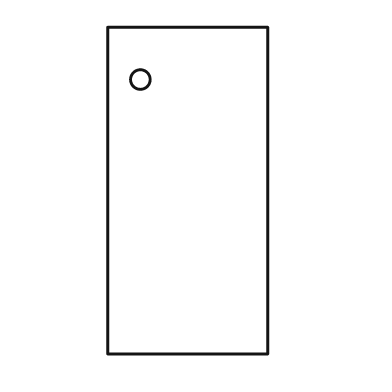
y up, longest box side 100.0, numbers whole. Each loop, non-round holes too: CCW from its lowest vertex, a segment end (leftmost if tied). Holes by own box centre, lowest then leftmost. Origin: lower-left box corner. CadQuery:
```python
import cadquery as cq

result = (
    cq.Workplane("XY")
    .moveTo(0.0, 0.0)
    .lineTo(49.0, 0.0)
    .lineTo(49.0, 100.0)
    .lineTo(0.0, 100.0)
    .close()
    .moveTo(10.0, 84.0)
    .circle(3.0)
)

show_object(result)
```